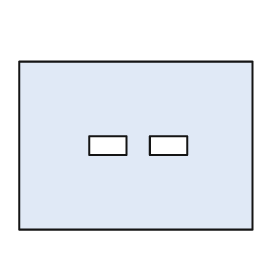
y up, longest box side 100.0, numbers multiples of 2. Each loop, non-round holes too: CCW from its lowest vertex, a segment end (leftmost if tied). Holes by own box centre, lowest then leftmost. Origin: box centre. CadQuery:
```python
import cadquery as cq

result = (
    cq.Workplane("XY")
    .moveTo(-50.0, -36.0)
    .lineTo(50.0, -36.0)
    .lineTo(50.0, 36.0)
    .lineTo(-50.0, 36.0)
    .close()
    .moveTo(-20.0, -4.0)
    .lineTo(-4.0, -4.0)
    .lineTo(-4.0, 4.0)
    .lineTo(-20.0, 4.0)
    .close()
    .moveTo(6.0, -4.0)
    .lineTo(22.0, -4.0)
    .lineTo(22.0, 4.0)
    .lineTo(6.0, 4.0)
    .close()
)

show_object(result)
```